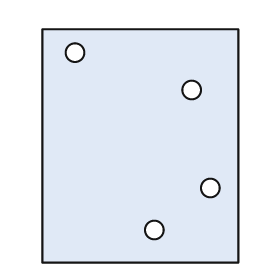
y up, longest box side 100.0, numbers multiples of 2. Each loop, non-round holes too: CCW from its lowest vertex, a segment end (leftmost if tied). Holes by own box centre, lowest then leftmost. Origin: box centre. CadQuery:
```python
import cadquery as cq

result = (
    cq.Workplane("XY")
    .moveTo(-42.0, -50.0)
    .lineTo(42.0, -50.0)
    .lineTo(42.0, 50.0)
    .lineTo(-42.0, 50.0)
    .close()
    .moveTo(6.0, -36.0)
    .circle(4.0)
    .moveTo(30.0, -18.0)
    .circle(4.0)
    .moveTo(22.0, 24.0)
    .circle(4.0)
    .moveTo(-28.0, 40.0)
    .circle(4.0)
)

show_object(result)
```